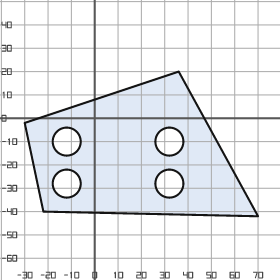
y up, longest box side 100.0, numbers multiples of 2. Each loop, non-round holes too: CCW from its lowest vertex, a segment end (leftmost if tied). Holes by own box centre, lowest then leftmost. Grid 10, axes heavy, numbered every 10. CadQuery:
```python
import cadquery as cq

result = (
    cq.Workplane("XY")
    .moveTo(70.0, -42.0)
    .lineTo(36.0, 20.0)
    .lineTo(-30.0, -2.0)
    .lineTo(-22.0, -40.0)
    .close()
    .moveTo(-12.0, -28.0)
    .circle(6.0)
    .moveTo(32.0, -28.0)
    .circle(6.0)
    .moveTo(-12.0, -10.0)
    .circle(6.0)
    .moveTo(32.0, -10.0)
    .circle(6.0)
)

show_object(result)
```